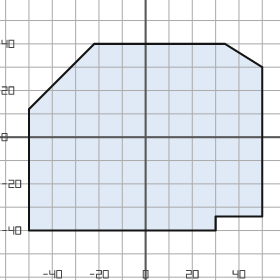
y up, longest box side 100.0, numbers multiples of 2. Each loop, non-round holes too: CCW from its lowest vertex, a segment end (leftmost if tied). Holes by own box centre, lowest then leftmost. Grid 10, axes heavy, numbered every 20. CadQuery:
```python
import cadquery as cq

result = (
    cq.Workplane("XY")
    .moveTo(-50.0, -40.0)
    .lineTo(30.0, -40.0)
    .lineTo(30.0, -34.0)
    .lineTo(50.0, -34.0)
    .lineTo(50.0, 30.0)
    .lineTo(34.0, 40.0)
    .lineTo(-22.0, 40.0)
    .lineTo(-50.0, 12.0)
    .close()
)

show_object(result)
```